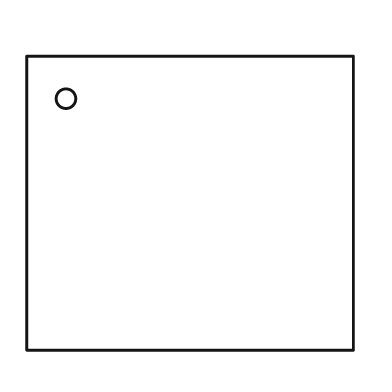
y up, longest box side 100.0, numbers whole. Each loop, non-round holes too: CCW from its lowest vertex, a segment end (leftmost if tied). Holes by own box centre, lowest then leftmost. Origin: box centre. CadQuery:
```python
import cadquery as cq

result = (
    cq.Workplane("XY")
    .moveTo(-50.0, -45.0)
    .lineTo(50.0, -45.0)
    .lineTo(50.0, 45.0)
    .lineTo(-50.0, 45.0)
    .close()
    .moveTo(-38.0, 32.0)
    .circle(3.0)
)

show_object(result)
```